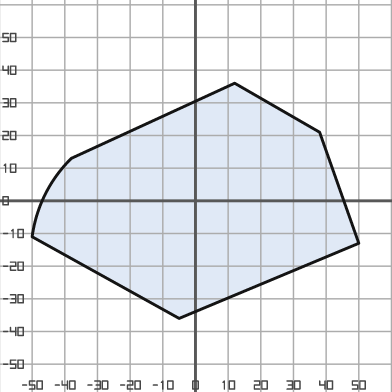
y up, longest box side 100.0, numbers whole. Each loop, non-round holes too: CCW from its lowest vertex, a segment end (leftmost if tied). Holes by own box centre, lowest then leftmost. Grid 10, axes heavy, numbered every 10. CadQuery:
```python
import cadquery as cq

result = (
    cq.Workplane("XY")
    .moveTo(-5.0, -36.0)
    .lineTo(50.0, -13.0)
    .lineTo(38.0, 21.0)
    .lineTo(12.0, 36.0)
    .lineTo(-38.0, 13.0)
    .threePointArc((-46.0, 2.0), (-50.0, -11.0))
    .close()
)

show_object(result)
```